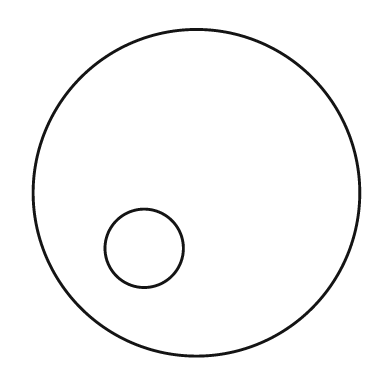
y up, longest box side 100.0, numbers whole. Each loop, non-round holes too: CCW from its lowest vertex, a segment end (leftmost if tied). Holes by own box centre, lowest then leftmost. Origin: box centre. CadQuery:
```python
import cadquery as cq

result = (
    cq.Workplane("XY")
    .moveTo(0.0, 0.0)
    .circle(50.0)
    .moveTo(-16.0, -17.0)
    .circle(12.0)
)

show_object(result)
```